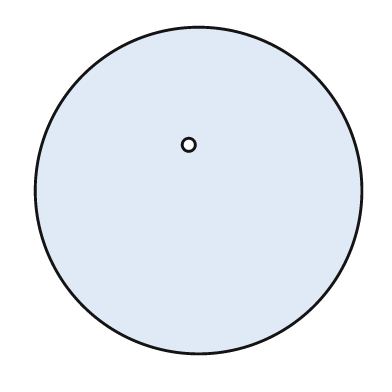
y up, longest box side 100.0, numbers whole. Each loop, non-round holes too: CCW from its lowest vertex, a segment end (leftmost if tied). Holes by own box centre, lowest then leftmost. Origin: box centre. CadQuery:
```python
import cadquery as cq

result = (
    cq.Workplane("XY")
    .moveTo(0.0, 0.0)
    .circle(50.0)
    .moveTo(-3.0, 14.0)
    .circle(2.0)
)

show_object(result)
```